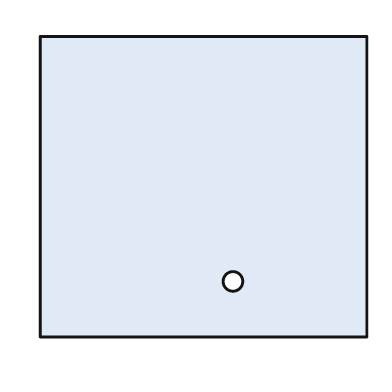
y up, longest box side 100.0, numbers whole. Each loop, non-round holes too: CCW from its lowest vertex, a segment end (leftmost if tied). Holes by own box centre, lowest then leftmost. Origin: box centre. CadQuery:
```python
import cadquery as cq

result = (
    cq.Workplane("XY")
    .moveTo(-50.0, -46.0)
    .lineTo(50.0, -46.0)
    .lineTo(50.0, 46.0)
    .lineTo(-50.0, 46.0)
    .close()
    .moveTo(9.0, -29.0)
    .circle(3.0)
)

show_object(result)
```